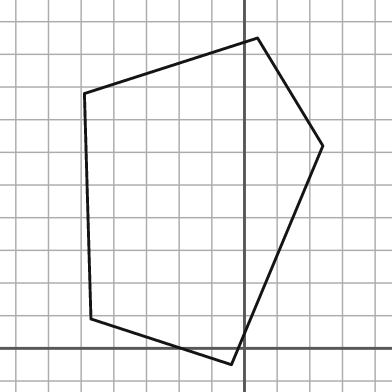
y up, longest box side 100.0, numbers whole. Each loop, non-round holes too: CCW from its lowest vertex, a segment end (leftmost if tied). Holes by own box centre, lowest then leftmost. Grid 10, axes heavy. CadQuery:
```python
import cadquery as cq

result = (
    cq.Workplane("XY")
    .moveTo(-4.0, -5.0)
    .lineTo(24.0, 62.0)
    .lineTo(4.0, 95.0)
    .lineTo(-49.0, 78.0)
    .lineTo(-47.0, 9.0)
    .close()
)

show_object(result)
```